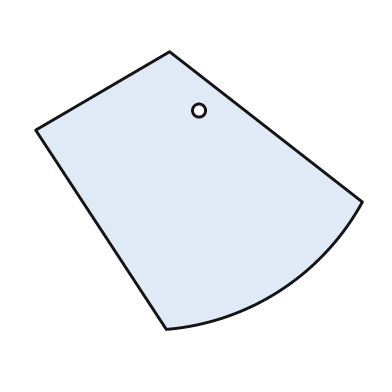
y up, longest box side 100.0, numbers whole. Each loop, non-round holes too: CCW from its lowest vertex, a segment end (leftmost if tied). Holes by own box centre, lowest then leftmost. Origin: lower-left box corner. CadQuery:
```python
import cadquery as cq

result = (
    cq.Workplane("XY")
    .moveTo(40.0, 0.0)
    .threePointArc((75.0, 12.0), (100.0, 39.0))
    .lineTo(41.0, 85.0)
    .lineTo(0.0, 61.0)
    .close()
    .moveTo(50.0, 67.0)
    .circle(2.0)
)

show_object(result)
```